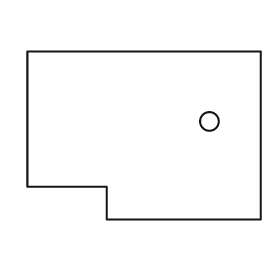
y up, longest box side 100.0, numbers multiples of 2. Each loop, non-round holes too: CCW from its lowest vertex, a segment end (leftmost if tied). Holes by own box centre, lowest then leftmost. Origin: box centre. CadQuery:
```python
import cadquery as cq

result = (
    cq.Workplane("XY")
    .moveTo(-16.0, -36.0)
    .lineTo(50.0, -36.0)
    .lineTo(50.0, 36.0)
    .lineTo(-50.0, 36.0)
    .lineTo(-50.0, -22.0)
    .lineTo(-16.0, -22.0)
    .close()
    .moveTo(28.0, 6.0)
    .circle(4.0)
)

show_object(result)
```